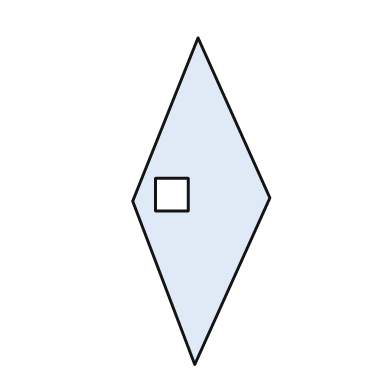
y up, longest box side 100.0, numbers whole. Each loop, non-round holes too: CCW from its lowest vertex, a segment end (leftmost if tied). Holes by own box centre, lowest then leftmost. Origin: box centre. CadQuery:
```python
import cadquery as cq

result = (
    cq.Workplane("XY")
    .moveTo(-2.0, -50.0)
    .lineTo(21.0, 1.0)
    .lineTo(-1.0, 50.0)
    .lineTo(-21.0, 0.0)
    .close()
    .moveTo(-14.0, -3.0)
    .lineTo(-4.0, -3.0)
    .lineTo(-4.0, 7.0)
    .lineTo(-14.0, 7.0)
    .close()
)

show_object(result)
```